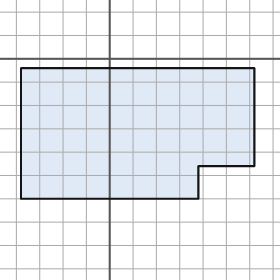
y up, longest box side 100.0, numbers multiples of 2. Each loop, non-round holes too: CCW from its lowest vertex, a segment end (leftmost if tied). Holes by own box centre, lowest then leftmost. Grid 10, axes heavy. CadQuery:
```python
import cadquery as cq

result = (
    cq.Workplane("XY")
    .moveTo(-38.0, -60.0)
    .lineTo(38.0, -60.0)
    .lineTo(38.0, -46.0)
    .lineTo(62.0, -46.0)
    .lineTo(62.0, -4.0)
    .lineTo(-38.0, -4.0)
    .close()
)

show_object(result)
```